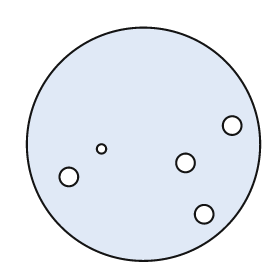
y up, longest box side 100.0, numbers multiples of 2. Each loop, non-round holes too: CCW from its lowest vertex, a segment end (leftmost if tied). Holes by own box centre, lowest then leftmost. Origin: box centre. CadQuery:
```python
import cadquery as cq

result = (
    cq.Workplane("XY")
    .moveTo(0.0, 0.0)
    .circle(50.0)
    .moveTo(26.0, -30.0)
    .circle(4.0)
    .moveTo(-32.0, -14.0)
    .circle(4.0)
    .moveTo(18.0, -8.0)
    .circle(4.0)
    .moveTo(-18.0, -2.0)
    .circle(2.0)
    .moveTo(38.0, 8.0)
    .circle(4.0)
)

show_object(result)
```